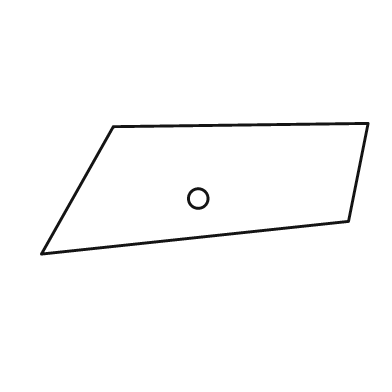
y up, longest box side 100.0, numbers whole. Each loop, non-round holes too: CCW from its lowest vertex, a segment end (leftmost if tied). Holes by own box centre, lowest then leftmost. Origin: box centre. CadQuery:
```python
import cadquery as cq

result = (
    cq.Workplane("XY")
    .moveTo(-50.0, -20.0)
    .lineTo(44.0, -10.0)
    .lineTo(50.0, 20.0)
    .lineTo(-28.0, 19.0)
    .close()
    .moveTo(-2.0, -3.0)
    .circle(3.0)
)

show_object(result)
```